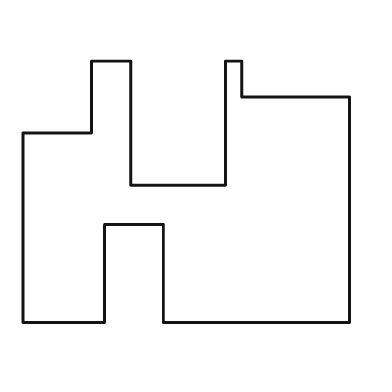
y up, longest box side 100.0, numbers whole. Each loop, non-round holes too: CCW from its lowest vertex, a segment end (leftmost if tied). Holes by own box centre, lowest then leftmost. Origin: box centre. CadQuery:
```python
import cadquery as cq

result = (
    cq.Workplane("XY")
    .moveTo(-50.0, -40.0)
    .lineTo(-25.0, -40.0)
    .lineTo(-25.0, -10.0)
    .lineTo(-7.0, -10.0)
    .lineTo(-7.0, -40.0)
    .lineTo(50.0, -40.0)
    .lineTo(50.0, 29.0)
    .lineTo(17.0, 29.0)
    .lineTo(17.0, 40.0)
    .lineTo(12.0, 40.0)
    .lineTo(12.0, 2.0)
    .lineTo(-17.0, 2.0)
    .lineTo(-17.0, 40.0)
    .lineTo(-29.0, 40.0)
    .lineTo(-29.0, 18.0)
    .lineTo(-50.0, 18.0)
    .close()
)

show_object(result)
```